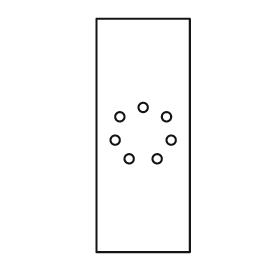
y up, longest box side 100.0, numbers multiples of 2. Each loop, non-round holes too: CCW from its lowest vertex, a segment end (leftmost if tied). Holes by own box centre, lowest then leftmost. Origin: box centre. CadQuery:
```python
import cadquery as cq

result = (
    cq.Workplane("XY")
    .moveTo(-20.0, -50.0)
    .lineTo(20.0, -50.0)
    .lineTo(20.0, 50.0)
    .lineTo(-20.0, 50.0)
    .close()
    .moveTo(-6.0, -10.0)
    .circle(2.0)
    .moveTo(6.0, -10.0)
    .circle(2.0)
    .moveTo(-12.0, -2.0)
    .circle(2.0)
    .moveTo(12.0, -2.0)
    .circle(2.0)
    .moveTo(-10.0, 8.0)
    .circle(2.0)
    .moveTo(10.0, 8.0)
    .circle(2.0)
    .moveTo(0.0, 12.0)
    .circle(2.0)
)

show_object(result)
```